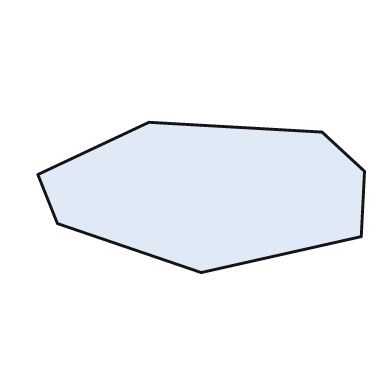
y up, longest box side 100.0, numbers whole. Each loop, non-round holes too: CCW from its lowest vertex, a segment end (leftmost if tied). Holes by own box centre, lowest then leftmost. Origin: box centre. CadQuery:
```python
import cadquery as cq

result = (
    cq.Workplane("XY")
    .moveTo(0.0, -23.0)
    .lineTo(49.0, -12.0)
    .lineTo(50.0, 8.0)
    .lineTo(37.0, 20.0)
    .lineTo(-16.0, 23.0)
    .lineTo(-50.0, 7.0)
    .lineTo(-44.0, -8.0)
    .close()
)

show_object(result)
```